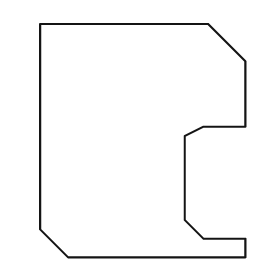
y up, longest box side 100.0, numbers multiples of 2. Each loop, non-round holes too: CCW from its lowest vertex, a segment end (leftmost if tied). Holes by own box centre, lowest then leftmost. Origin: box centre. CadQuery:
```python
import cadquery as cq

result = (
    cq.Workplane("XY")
    .moveTo(-32.0, -50.0)
    .lineTo(44.0, -50.0)
    .lineTo(44.0, -42.0)
    .lineTo(26.0, -42.0)
    .lineTo(18.0, -34.0)
    .lineTo(18.0, 2.0)
    .lineTo(26.0, 6.0)
    .lineTo(44.0, 6.0)
    .lineTo(44.0, 34.0)
    .lineTo(28.0, 50.0)
    .lineTo(-44.0, 50.0)
    .lineTo(-44.0, -38.0)
    .close()
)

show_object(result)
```